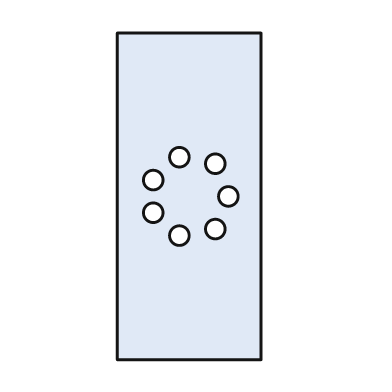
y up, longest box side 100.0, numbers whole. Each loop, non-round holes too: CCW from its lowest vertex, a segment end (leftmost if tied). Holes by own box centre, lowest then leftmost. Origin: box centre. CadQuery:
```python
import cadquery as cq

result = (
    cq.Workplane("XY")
    .moveTo(-22.0, -50.0)
    .lineTo(22.0, -50.0)
    .lineTo(22.0, 50.0)
    .lineTo(-22.0, 50.0)
    .close()
    .moveTo(-3.0, -12.0)
    .circle(3.0)
    .moveTo(8.0, -10.0)
    .circle(3.0)
    .moveTo(-11.0, -5.0)
    .circle(3.0)
    .moveTo(12.0, 0.0)
    .circle(3.0)
    .moveTo(-11.0, 5.0)
    .circle(3.0)
    .moveTo(8.0, 10.0)
    .circle(3.0)
    .moveTo(-3.0, 12.0)
    .circle(3.0)
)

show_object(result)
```